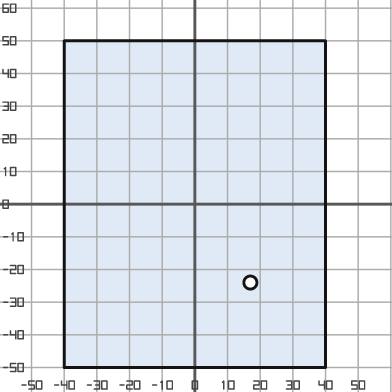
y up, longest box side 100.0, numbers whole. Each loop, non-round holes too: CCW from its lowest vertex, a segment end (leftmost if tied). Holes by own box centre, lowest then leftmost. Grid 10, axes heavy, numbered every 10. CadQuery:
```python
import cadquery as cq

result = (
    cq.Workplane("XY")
    .moveTo(-40.0, -50.0)
    .lineTo(40.0, -50.0)
    .lineTo(40.0, 50.0)
    .lineTo(-40.0, 50.0)
    .close()
    .moveTo(17.0, -24.0)
    .circle(2.0)
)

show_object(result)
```